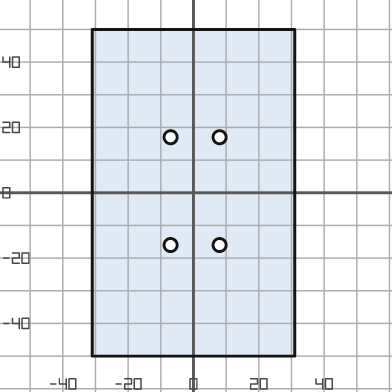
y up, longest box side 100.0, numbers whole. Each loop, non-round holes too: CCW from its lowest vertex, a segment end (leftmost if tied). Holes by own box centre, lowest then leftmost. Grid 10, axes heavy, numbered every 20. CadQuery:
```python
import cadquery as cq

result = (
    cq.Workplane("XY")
    .moveTo(-31.0, -50.0)
    .lineTo(31.0, -50.0)
    .lineTo(31.0, 50.0)
    .lineTo(-31.0, 50.0)
    .close()
    .moveTo(-7.0, -16.0)
    .circle(2.0)
    .moveTo(8.0, -16.0)
    .circle(2.0)
    .moveTo(-7.0, 17.0)
    .circle(2.0)
    .moveTo(8.0, 17.0)
    .circle(2.0)
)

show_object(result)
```